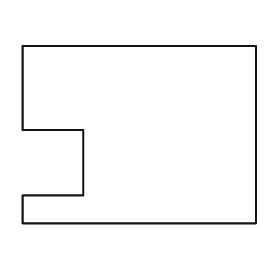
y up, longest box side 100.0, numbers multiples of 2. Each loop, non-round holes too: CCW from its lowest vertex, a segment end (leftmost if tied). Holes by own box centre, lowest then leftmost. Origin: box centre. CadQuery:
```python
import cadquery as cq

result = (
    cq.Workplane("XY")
    .moveTo(-50.0, -38.0)
    .lineTo(50.0, -38.0)
    .lineTo(50.0, 38.0)
    .lineTo(-50.0, 38.0)
    .lineTo(-50.0, 2.0)
    .lineTo(-24.0, 2.0)
    .lineTo(-24.0, -26.0)
    .lineTo(-50.0, -26.0)
    .close()
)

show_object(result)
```